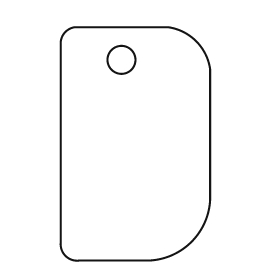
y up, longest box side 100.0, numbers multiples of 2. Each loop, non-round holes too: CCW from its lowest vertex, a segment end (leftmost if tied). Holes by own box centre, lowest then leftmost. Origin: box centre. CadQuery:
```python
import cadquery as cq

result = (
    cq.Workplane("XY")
    .moveTo(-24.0, -50.0)
    .lineTo(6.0, -50.0)
    .threePointArc((24.0, -42.0), (32.0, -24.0))
    .lineTo(32.0, 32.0)
    .threePointArc((26.0, 44.0), (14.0, 50.0))
    .lineTo(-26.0, 50.0)
    .threePointArc((-30.0, 48.0), (-32.0, 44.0))
    .lineTo(-32.0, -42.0)
    .threePointArc((-30.0, -48.0), (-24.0, -50.0))
    .close()
    .moveTo(-6.0, 36.0)
    .circle(6.0)
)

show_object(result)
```